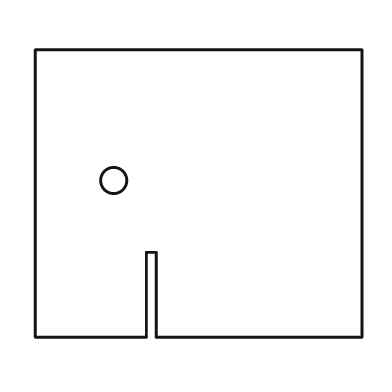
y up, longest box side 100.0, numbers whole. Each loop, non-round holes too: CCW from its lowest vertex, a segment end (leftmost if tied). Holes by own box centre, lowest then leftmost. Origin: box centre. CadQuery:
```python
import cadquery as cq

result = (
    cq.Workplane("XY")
    .moveTo(-50.0, -44.0)
    .lineTo(-16.0, -44.0)
    .lineTo(-16.0, -18.0)
    .lineTo(-13.0, -18.0)
    .lineTo(-13.0, -44.0)
    .lineTo(50.0, -44.0)
    .lineTo(50.0, 44.0)
    .lineTo(-50.0, 44.0)
    .close()
    .moveTo(-26.0, 4.0)
    .circle(4.0)
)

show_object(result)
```